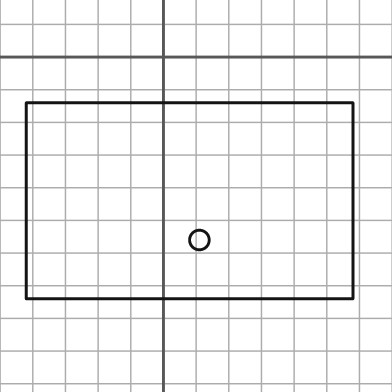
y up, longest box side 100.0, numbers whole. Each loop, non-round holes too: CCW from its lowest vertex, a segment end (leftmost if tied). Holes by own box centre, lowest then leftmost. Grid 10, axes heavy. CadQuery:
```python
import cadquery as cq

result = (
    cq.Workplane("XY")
    .moveTo(-42.0, -74.0)
    .lineTo(58.0, -74.0)
    .lineTo(58.0, -14.0)
    .lineTo(-42.0, -14.0)
    .close()
    .moveTo(11.0, -56.0)
    .circle(3.0)
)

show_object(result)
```